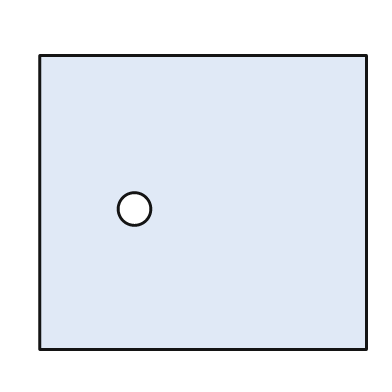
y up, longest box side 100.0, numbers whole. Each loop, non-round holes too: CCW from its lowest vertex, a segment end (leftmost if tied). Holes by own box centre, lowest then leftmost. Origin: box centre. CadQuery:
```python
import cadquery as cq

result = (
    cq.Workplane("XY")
    .moveTo(-50.0, -45.0)
    .lineTo(50.0, -45.0)
    .lineTo(50.0, 45.0)
    .lineTo(-50.0, 45.0)
    .close()
    .moveTo(-21.0, -2.0)
    .circle(5.0)
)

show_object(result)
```